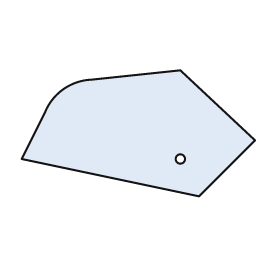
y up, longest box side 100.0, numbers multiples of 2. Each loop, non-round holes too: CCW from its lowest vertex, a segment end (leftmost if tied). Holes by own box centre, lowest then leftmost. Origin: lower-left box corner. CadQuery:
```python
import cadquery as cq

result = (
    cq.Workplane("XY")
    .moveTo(76.0, 0.0)
    .lineTo(100.0, 24.0)
    .lineTo(68.0, 54.0)
    .lineTo(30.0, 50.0)
    .threePointArc((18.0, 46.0), (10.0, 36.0))
    .lineTo(0.0, 16.0)
    .close()
    .moveTo(68.0, 16.0)
    .circle(2.0)
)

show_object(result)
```